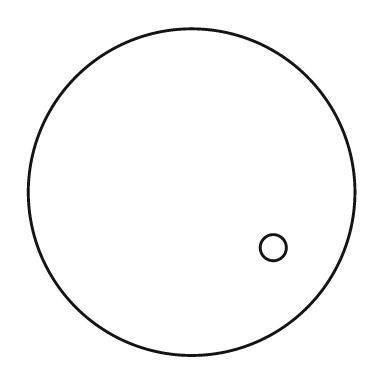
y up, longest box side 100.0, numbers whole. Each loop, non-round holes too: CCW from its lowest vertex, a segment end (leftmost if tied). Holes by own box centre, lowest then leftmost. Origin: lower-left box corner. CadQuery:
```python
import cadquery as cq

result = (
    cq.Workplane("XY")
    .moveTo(50.0, 50.0)
    .circle(50.0)
    .moveTo(75.0, 33.0)
    .circle(4.0)
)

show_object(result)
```